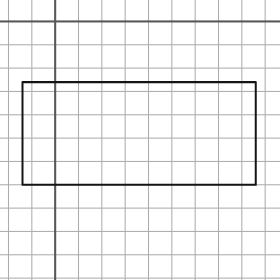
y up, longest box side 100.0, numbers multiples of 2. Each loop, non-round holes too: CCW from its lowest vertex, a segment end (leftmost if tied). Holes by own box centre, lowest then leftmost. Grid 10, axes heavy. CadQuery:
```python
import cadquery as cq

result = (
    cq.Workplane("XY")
    .moveTo(-14.0, -70.0)
    .lineTo(86.0, -70.0)
    .lineTo(86.0, -26.0)
    .lineTo(-14.0, -26.0)
    .close()
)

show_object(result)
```